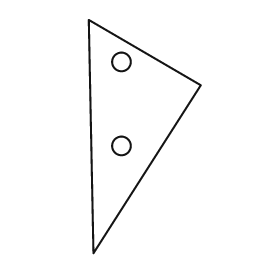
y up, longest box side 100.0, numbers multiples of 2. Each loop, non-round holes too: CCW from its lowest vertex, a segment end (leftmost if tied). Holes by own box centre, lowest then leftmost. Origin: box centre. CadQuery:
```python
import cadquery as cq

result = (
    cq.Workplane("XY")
    .moveTo(-22.0, -50.0)
    .lineTo(24.0, 22.0)
    .lineTo(-24.0, 50.0)
    .close()
    .moveTo(-10.0, -4.0)
    .circle(4.0)
    .moveTo(-10.0, 32.0)
    .circle(4.0)
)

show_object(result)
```